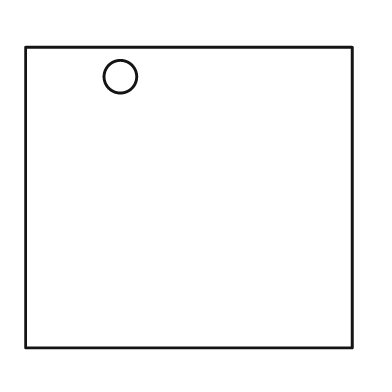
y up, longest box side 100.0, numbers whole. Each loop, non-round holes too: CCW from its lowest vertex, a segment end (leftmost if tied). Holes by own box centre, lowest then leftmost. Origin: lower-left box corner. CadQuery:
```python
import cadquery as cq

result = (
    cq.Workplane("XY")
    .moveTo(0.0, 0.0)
    .lineTo(100.0, 0.0)
    .lineTo(100.0, 92.0)
    .lineTo(0.0, 92.0)
    .close()
    .moveTo(29.0, 83.0)
    .circle(5.0)
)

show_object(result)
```